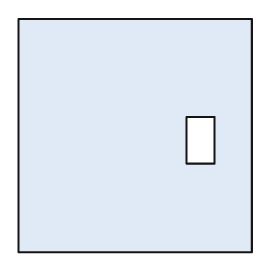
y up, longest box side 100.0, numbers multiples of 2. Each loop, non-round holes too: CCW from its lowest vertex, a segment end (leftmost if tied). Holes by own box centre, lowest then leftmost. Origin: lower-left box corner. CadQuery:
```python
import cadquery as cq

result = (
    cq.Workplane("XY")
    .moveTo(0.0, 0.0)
    .lineTo(100.0, 0.0)
    .lineTo(100.0, 100.0)
    .lineTo(0.0, 100.0)
    .close()
    .moveTo(72.0, 38.0)
    .lineTo(84.0, 38.0)
    .lineTo(84.0, 58.0)
    .lineTo(72.0, 58.0)
    .close()
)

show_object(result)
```